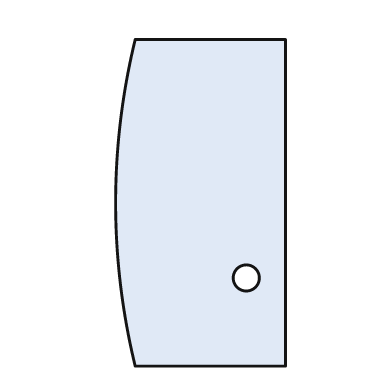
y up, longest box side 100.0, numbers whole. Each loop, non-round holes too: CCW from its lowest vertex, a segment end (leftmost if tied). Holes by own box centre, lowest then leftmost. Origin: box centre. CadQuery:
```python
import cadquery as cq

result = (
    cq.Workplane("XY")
    .moveTo(-20.0, -50.0)
    .lineTo(26.0, -50.0)
    .lineTo(26.0, 50.0)
    .lineTo(-20.0, 50.0)
    .threePointArc((-26.0, 0.0), (-20.0, -50.0))
    .close()
    .moveTo(14.0, -23.0)
    .circle(4.0)
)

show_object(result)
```